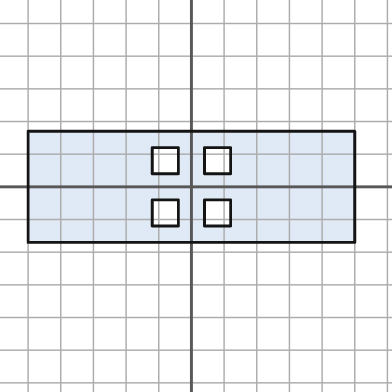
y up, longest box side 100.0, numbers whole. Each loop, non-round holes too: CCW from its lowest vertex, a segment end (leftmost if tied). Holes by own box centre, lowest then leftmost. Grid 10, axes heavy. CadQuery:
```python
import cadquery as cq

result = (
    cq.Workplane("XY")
    .moveTo(-50.0, -17.0)
    .lineTo(50.0, -17.0)
    .lineTo(50.0, 17.0)
    .lineTo(-50.0, 17.0)
    .close()
    .moveTo(-12.0, -12.0)
    .lineTo(-4.0, -12.0)
    .lineTo(-4.0, -4.0)
    .lineTo(-12.0, -4.0)
    .close()
    .moveTo(4.0, -12.0)
    .lineTo(12.0, -12.0)
    .lineTo(12.0, -4.0)
    .lineTo(4.0, -4.0)
    .close()
    .moveTo(-12.0, 4.0)
    .lineTo(-4.0, 4.0)
    .lineTo(-4.0, 12.0)
    .lineTo(-12.0, 12.0)
    .close()
    .moveTo(4.0, 4.0)
    .lineTo(12.0, 4.0)
    .lineTo(12.0, 12.0)
    .lineTo(4.0, 12.0)
    .close()
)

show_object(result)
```